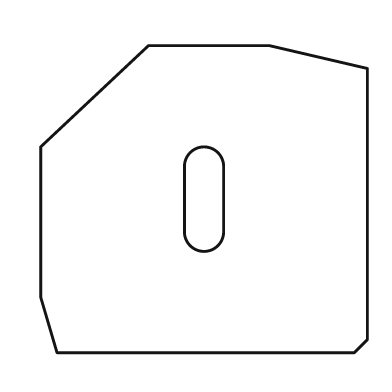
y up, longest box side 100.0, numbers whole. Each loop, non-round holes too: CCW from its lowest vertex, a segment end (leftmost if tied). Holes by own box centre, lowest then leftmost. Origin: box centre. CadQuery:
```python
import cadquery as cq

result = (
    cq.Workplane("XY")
    .moveTo(-45.0, -47.0)
    .lineTo(46.0, -47.0)
    .lineTo(50.0, -43.0)
    .lineTo(50.0, 40.0)
    .lineTo(20.0, 47.0)
    .lineTo(-17.0, 47.0)
    .lineTo(-50.0, 16.0)
    .lineTo(-50.0, -30.0)
    .close()
    .moveTo(-6.0, -10.0)
    .threePointArc((0.0, -16.0), (6.0, -10.0))
    .lineTo(6.0, 10.0)
    .threePointArc((0.0, 16.0), (-6.0, 10.0))
    .close()
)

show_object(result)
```